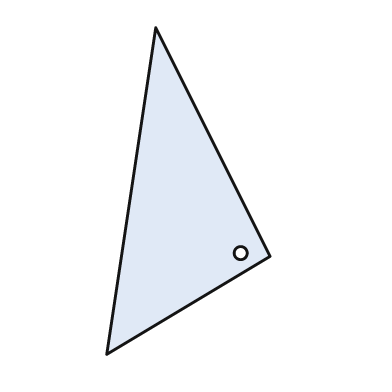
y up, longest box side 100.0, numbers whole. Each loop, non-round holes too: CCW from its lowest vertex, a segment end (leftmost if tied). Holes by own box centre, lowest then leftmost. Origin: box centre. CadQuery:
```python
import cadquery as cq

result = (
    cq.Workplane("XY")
    .moveTo(-25.0, -50.0)
    .lineTo(25.0, -20.0)
    .lineTo(-10.0, 50.0)
    .close()
    .moveTo(16.0, -19.0)
    .circle(2.0)
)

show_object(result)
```